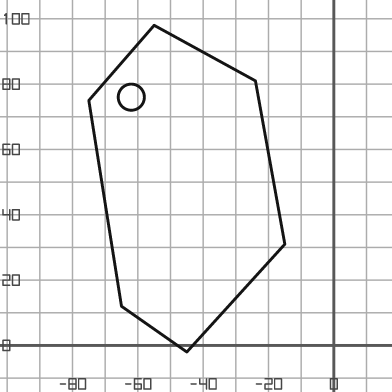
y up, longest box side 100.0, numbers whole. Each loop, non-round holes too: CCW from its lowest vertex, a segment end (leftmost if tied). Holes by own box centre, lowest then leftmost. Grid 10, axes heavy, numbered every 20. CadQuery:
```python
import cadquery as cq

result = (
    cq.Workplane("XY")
    .moveTo(-45.0, -2.0)
    .lineTo(-15.0, 31.0)
    .lineTo(-24.0, 81.0)
    .lineTo(-55.0, 98.0)
    .lineTo(-75.0, 75.0)
    .lineTo(-65.0, 12.0)
    .close()
    .moveTo(-62.0, 76.0)
    .circle(4.0)
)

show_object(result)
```